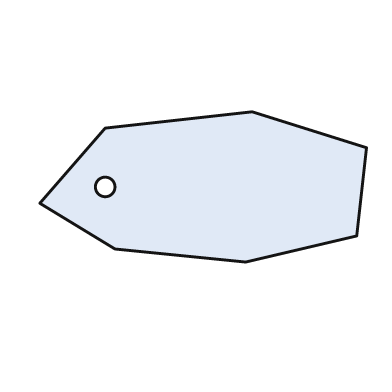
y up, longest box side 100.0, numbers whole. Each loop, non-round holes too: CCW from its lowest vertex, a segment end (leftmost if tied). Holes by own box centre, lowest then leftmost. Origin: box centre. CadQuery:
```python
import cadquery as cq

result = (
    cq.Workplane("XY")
    .moveTo(13.0, -23.0)
    .lineTo(47.0, -15.0)
    .lineTo(50.0, 12.0)
    .lineTo(15.0, 23.0)
    .lineTo(-30.0, 18.0)
    .lineTo(-50.0, -5.0)
    .lineTo(-27.0, -19.0)
    .close()
    .moveTo(-30.0, 0.0)
    .circle(3.0)
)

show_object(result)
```